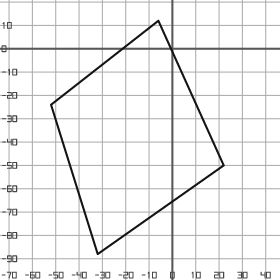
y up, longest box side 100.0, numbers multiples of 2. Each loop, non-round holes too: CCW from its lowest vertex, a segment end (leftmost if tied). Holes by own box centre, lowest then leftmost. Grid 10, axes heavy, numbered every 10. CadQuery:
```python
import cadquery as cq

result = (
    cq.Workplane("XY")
    .moveTo(-32.0, -88.0)
    .lineTo(22.0, -50.0)
    .lineTo(-6.0, 12.0)
    .lineTo(-52.0, -24.0)
    .close()
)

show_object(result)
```